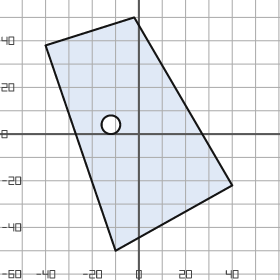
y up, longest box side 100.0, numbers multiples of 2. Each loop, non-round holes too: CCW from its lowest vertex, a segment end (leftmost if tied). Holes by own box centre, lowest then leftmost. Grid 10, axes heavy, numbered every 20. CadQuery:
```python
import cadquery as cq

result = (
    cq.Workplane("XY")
    .moveTo(-10.0, -50.0)
    .lineTo(40.0, -22.0)
    .lineTo(-2.0, 50.0)
    .lineTo(-40.0, 38.0)
    .close()
    .moveTo(-12.0, 4.0)
    .circle(4.0)
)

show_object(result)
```